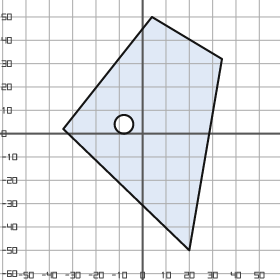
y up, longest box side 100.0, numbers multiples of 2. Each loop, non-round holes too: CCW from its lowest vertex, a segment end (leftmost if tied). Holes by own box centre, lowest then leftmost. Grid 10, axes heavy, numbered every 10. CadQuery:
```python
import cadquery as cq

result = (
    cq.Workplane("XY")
    .moveTo(20.0, -50.0)
    .lineTo(34.0, 32.0)
    .lineTo(4.0, 50.0)
    .lineTo(-34.0, 2.0)
    .close()
    .moveTo(-8.0, 4.0)
    .circle(4.0)
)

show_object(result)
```